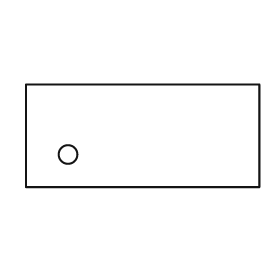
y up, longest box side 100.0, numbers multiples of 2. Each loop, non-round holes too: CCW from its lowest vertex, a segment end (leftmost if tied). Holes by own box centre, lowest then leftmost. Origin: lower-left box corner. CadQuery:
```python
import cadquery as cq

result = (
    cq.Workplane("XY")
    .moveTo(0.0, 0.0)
    .lineTo(100.0, 0.0)
    .lineTo(100.0, 44.0)
    .lineTo(0.0, 44.0)
    .close()
    .moveTo(18.0, 14.0)
    .circle(4.0)
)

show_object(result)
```